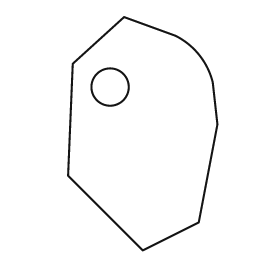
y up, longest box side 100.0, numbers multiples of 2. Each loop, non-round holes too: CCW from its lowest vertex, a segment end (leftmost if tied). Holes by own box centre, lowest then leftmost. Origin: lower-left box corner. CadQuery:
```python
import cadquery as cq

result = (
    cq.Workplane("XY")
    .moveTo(32.0, 0.0)
    .lineTo(56.0, 12.0)
    .lineTo(64.0, 54.0)
    .lineTo(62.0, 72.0)
    .threePointArc((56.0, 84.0), (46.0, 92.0))
    .lineTo(24.0, 100.0)
    .lineTo(2.0, 80.0)
    .lineTo(0.0, 32.0)
    .close()
    .moveTo(18.0, 70.0)
    .circle(8.0)
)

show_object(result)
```